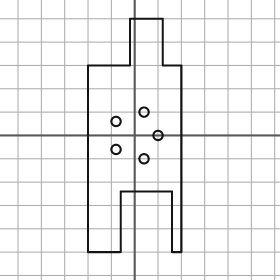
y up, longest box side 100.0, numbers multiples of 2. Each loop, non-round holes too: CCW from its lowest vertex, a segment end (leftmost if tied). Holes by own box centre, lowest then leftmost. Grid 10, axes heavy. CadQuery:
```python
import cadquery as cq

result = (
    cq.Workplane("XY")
    .moveTo(-20.0, -50.0)
    .lineTo(-6.0, -50.0)
    .lineTo(-6.0, -24.0)
    .lineTo(16.0, -24.0)
    .lineTo(16.0, -50.0)
    .lineTo(20.0, -50.0)
    .lineTo(20.0, 30.0)
    .lineTo(12.0, 30.0)
    .lineTo(12.0, 50.0)
    .lineTo(-2.0, 50.0)
    .lineTo(-2.0, 30.0)
    .lineTo(-20.0, 30.0)
    .close()
    .moveTo(4.0, -10.0)
    .circle(2.0)
    .moveTo(-8.0, -6.0)
    .circle(2.0)
    .moveTo(10.0, 0.0)
    .circle(2.0)
    .moveTo(-8.0, 6.0)
    .circle(2.0)
    .moveTo(4.0, 10.0)
    .circle(2.0)
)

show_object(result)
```